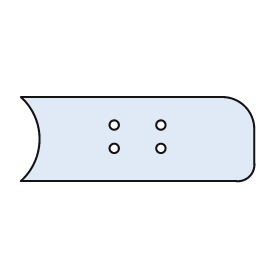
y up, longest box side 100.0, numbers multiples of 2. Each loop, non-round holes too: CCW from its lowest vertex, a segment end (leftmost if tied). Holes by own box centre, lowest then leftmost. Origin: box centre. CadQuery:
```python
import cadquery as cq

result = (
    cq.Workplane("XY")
    .moveTo(-50.0, -18.0)
    .lineTo(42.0, -18.0)
    .threePointArc((48.0, -16.0), (50.0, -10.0))
    .lineTo(50.0, 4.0)
    .threePointArc((46.0, 14.0), (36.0, 18.0))
    .lineTo(-50.0, 18.0)
    .threePointArc((-42.0, 0.0), (-50.0, -18.0))
    .close()
    .moveTo(-10.0, -4.0)
    .circle(2.0)
    .moveTo(10.0, -4.0)
    .circle(2.0)
    .moveTo(-10.0, 6.0)
    .circle(2.0)
    .moveTo(10.0, 6.0)
    .circle(2.0)
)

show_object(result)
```